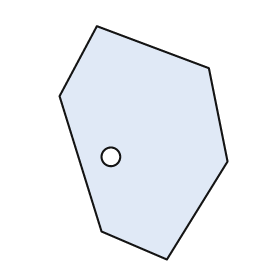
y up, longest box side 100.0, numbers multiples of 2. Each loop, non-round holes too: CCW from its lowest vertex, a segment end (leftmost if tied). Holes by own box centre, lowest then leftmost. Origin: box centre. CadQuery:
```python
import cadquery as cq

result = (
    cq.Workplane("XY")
    .moveTo(10.0, -50.0)
    .lineTo(36.0, -8.0)
    .lineTo(28.0, 32.0)
    .lineTo(-20.0, 50.0)
    .lineTo(-36.0, 20.0)
    .lineTo(-18.0, -38.0)
    .close()
    .moveTo(-14.0, -6.0)
    .circle(4.0)
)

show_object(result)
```